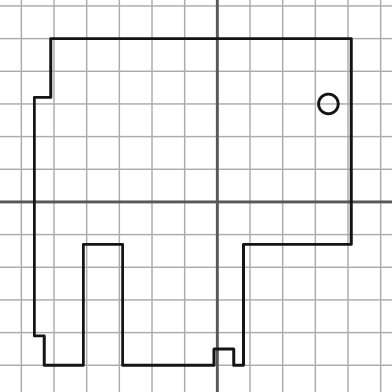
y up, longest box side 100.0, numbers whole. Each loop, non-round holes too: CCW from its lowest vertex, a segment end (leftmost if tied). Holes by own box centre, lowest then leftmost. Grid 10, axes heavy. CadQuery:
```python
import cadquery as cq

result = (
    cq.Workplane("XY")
    .moveTo(-53.0, -50.0)
    .lineTo(-41.0, -50.0)
    .lineTo(-41.0, -13.0)
    .lineTo(-29.0, -13.0)
    .lineTo(-29.0, -50.0)
    .lineTo(-1.0, -50.0)
    .lineTo(-1.0, -45.0)
    .lineTo(5.0, -45.0)
    .lineTo(5.0, -50.0)
    .lineTo(8.0, -50.0)
    .lineTo(8.0, -13.0)
    .lineTo(41.0, -13.0)
    .lineTo(41.0, 50.0)
    .lineTo(-51.0, 50.0)
    .lineTo(-51.0, 32.0)
    .lineTo(-56.0, 32.0)
    .lineTo(-56.0, -41.0)
    .lineTo(-53.0, -41.0)
    .close()
    .moveTo(34.0, 30.0)
    .circle(3.0)
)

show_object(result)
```